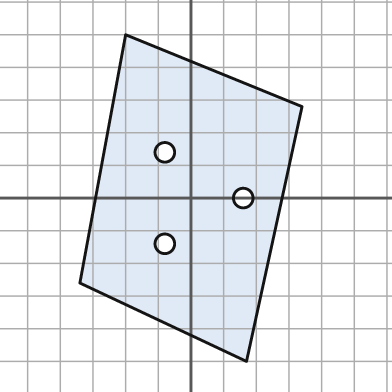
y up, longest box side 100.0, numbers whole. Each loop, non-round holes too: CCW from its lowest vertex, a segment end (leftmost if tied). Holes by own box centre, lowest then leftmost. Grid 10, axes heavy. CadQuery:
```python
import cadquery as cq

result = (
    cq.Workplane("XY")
    .moveTo(17.0, -50.0)
    .lineTo(34.0, 28.0)
    .lineTo(-20.0, 50.0)
    .lineTo(-34.0, -26.0)
    .close()
    .moveTo(-8.0, -14.0)
    .circle(3.0)
    .moveTo(16.0, 0.0)
    .circle(3.0)
    .moveTo(-8.0, 14.0)
    .circle(3.0)
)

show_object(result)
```